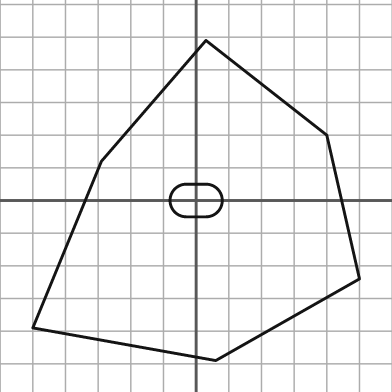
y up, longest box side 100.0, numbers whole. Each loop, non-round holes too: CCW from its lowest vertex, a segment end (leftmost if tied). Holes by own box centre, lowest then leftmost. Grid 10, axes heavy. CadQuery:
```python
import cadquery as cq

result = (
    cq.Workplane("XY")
    .moveTo(6.0, -49.0)
    .lineTo(50.0, -24.0)
    .lineTo(40.0, 20.0)
    .lineTo(3.0, 49.0)
    .lineTo(-29.0, 12.0)
    .lineTo(-50.0, -39.0)
    .close()
    .moveTo(-3.0, -5.0)
    .lineTo(3.0, -5.0)
    .threePointArc((8.0, 0.0), (3.0, 5.0))
    .lineTo(-3.0, 5.0)
    .threePointArc((-8.0, 0.0), (-3.0, -5.0))
    .close()
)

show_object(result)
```